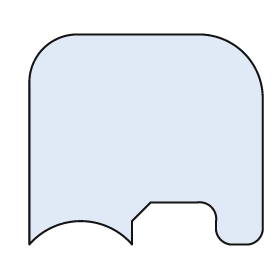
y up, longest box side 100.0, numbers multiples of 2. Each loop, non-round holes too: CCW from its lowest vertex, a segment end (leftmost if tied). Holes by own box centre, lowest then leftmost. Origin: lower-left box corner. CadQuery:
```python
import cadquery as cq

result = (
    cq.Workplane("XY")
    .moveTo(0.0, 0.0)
    .threePointArc((22.0, 10.0), (44.0, 0.0))
    .lineTo(44.0, 10.0)
    .lineTo(52.0, 18.0)
    .lineTo(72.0, 18.0)
    .threePointArc((78.0, 16.0), (80.0, 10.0))
    .lineTo(80.0, 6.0)
    .threePointArc((82.0, 2.0), (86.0, 0.0))
    .lineTo(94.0, 0.0)
    .threePointArc((98.0, 2.0), (100.0, 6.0))
    .lineTo(100.0, 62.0)
    .threePointArc((92.0, 82.0), (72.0, 90.0))
    .lineTo(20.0, 90.0)
    .threePointArc((6.0, 84.0), (0.0, 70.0))
    .close()
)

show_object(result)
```